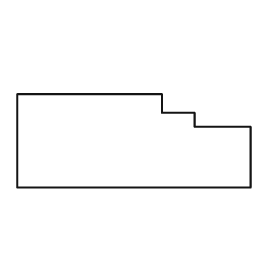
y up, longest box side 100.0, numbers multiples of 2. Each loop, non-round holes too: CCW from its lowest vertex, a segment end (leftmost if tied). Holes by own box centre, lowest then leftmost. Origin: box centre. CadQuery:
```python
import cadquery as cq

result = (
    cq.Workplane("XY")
    .moveTo(-50.0, -20.0)
    .lineTo(50.0, -20.0)
    .lineTo(50.0, 6.0)
    .lineTo(26.0, 6.0)
    .lineTo(26.0, 12.0)
    .lineTo(12.0, 12.0)
    .lineTo(12.0, 20.0)
    .lineTo(-50.0, 20.0)
    .close()
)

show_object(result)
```